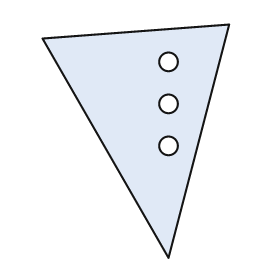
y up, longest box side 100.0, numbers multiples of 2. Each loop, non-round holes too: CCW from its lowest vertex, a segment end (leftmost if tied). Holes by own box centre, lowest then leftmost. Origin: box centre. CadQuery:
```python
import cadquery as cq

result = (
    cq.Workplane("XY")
    .moveTo(14.0, -50.0)
    .lineTo(40.0, 50.0)
    .lineTo(-40.0, 44.0)
    .close()
    .moveTo(14.0, -2.0)
    .circle(4.0)
    .moveTo(14.0, 16.0)
    .circle(4.0)
    .moveTo(14.0, 34.0)
    .circle(4.0)
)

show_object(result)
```